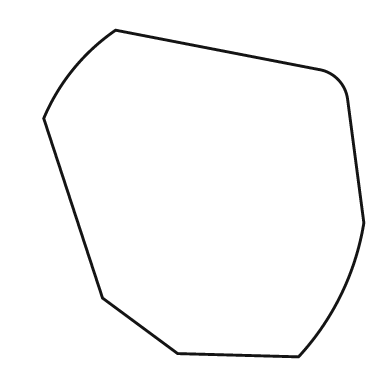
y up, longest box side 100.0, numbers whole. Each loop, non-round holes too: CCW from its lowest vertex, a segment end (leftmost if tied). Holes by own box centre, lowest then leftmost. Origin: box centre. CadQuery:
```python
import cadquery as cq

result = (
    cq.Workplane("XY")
    .moveTo(29.0, -50.0)
    .threePointArc((42.0, -31.0), (49.0, -9.0))
    .lineTo(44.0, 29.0)
    .threePointArc((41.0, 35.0), (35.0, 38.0))
    .lineTo(-27.0, 50.0)
    .threePointArc((-40.0, 38.0), (-49.0, 23.0))
    .lineTo(-31.0, -32.0)
    .lineTo(-8.0, -49.0)
    .close()
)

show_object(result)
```